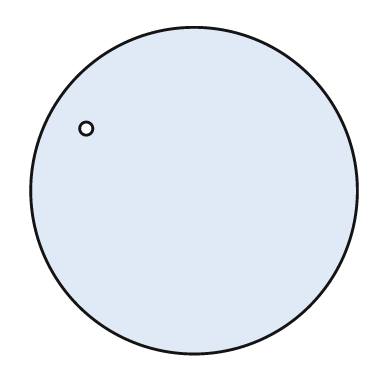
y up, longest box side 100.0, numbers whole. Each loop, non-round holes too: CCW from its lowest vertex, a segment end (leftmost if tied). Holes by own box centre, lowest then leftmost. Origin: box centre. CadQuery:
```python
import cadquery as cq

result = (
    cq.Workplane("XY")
    .moveTo(0.0, 0.0)
    .circle(50.0)
    .moveTo(-33.0, 19.0)
    .circle(2.0)
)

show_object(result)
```